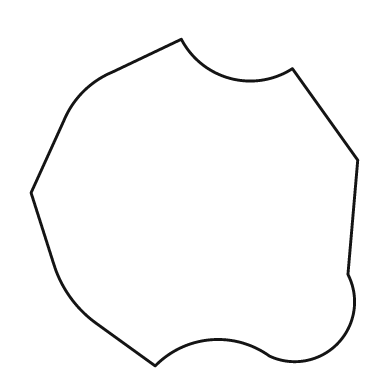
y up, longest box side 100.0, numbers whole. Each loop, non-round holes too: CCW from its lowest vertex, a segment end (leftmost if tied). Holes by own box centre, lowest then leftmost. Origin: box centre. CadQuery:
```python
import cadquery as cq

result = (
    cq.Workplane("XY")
    .moveTo(-12.0, -50.0)
    .threePointArc((5.0, -42.0), (23.0, -47.0))
    .threePointArc((44.0, -43.0), (47.0, -22.0))
    .lineTo(50.0, 13.0)
    .lineTo(30.0, 41.0)
    .threePointArc((11.0, 38.0), (-4.0, 50.0))
    .lineTo(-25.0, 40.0)
    .threePointArc((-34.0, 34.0), (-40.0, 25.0))
    .lineTo(-50.0, 3.0)
    .lineTo(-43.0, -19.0)
    .threePointArc((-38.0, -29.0), (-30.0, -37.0))
    .close()
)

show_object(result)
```